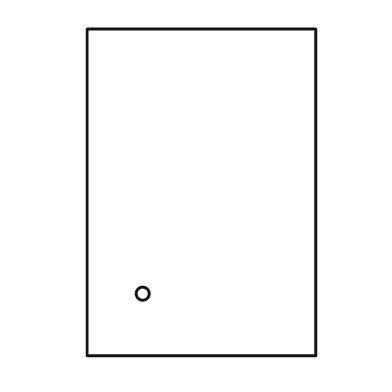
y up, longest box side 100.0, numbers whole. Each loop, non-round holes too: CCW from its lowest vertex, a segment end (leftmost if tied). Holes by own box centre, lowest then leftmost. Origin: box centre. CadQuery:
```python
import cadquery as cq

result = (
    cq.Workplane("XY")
    .moveTo(-35.0, -50.0)
    .lineTo(35.0, -50.0)
    .lineTo(35.0, 50.0)
    .lineTo(-35.0, 50.0)
    .close()
    .moveTo(-18.0, -31.0)
    .circle(2.0)
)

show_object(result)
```